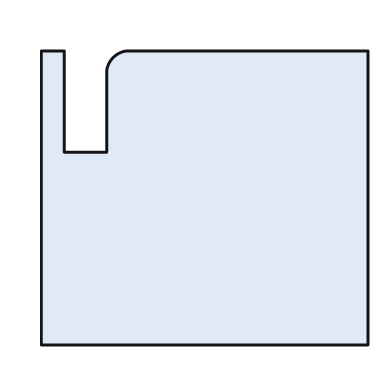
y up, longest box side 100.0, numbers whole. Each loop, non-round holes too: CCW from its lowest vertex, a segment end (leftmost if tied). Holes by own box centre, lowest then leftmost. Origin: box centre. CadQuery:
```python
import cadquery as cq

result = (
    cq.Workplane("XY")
    .moveTo(-50.0, -45.0)
    .lineTo(50.0, -45.0)
    .lineTo(50.0, 45.0)
    .lineTo(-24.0, 45.0)
    .threePointArc((-28.0, 43.0), (-30.0, 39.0))
    .lineTo(-30.0, 14.0)
    .lineTo(-43.0, 14.0)
    .lineTo(-43.0, 45.0)
    .lineTo(-50.0, 45.0)
    .close()
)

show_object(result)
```